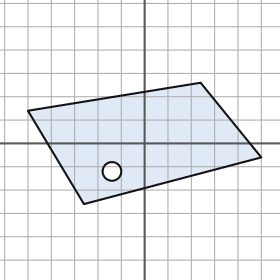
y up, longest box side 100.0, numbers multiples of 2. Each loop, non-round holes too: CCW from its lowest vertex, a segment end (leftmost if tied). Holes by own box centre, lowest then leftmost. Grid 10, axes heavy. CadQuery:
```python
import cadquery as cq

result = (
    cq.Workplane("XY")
    .moveTo(-26.0, -26.0)
    .lineTo(50.0, -6.0)
    .lineTo(24.0, 26.0)
    .lineTo(-50.0, 14.0)
    .close()
    .moveTo(-14.0, -12.0)
    .circle(4.0)
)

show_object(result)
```